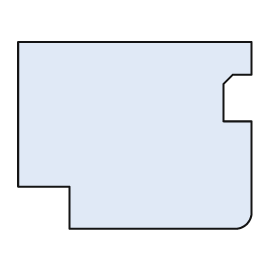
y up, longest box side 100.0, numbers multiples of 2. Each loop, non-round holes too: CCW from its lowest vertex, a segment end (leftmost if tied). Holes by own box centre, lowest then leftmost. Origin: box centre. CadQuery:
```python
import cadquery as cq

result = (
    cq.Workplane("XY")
    .moveTo(-28.0, -40.0)
    .lineTo(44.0, -40.0)
    .threePointArc((48.0, -38.0), (50.0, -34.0))
    .lineTo(50.0, 6.0)
    .lineTo(38.0, 6.0)
    .lineTo(38.0, 22.0)
    .lineTo(42.0, 26.0)
    .lineTo(50.0, 26.0)
    .lineTo(50.0, 40.0)
    .lineTo(-50.0, 40.0)
    .lineTo(-50.0, -22.0)
    .lineTo(-28.0, -22.0)
    .close()
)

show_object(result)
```